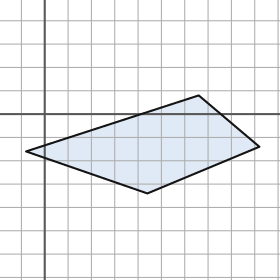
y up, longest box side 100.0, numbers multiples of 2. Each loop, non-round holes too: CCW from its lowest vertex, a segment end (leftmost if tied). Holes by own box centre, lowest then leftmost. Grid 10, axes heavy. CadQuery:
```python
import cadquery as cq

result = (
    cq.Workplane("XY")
    .moveTo(44.0, -34.0)
    .lineTo(92.0, -14.0)
    .lineTo(66.0, 8.0)
    .lineTo(-8.0, -16.0)
    .close()
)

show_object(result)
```